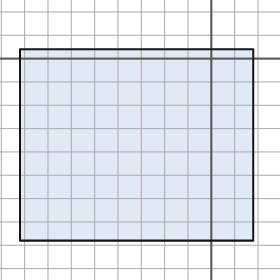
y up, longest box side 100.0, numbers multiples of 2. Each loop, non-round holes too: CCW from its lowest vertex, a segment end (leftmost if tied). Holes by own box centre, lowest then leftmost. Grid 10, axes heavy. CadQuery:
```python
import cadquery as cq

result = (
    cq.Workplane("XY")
    .moveTo(-82.0, -78.0)
    .lineTo(18.0, -78.0)
    .lineTo(18.0, 4.0)
    .lineTo(-82.0, 4.0)
    .close()
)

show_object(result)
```